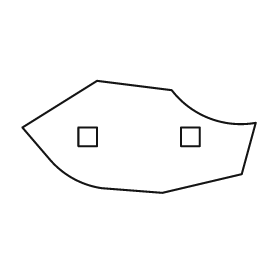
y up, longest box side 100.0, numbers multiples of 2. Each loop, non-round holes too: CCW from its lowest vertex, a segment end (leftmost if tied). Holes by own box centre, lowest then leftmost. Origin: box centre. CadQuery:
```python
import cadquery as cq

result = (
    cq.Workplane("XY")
    .moveTo(10.0, -24.0)
    .lineTo(44.0, -16.0)
    .lineTo(50.0, 6.0)
    .threePointArc((30.0, 8.0), (14.0, 20.0))
    .lineTo(-18.0, 24.0)
    .lineTo(-50.0, 4.0)
    .lineTo(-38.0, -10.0)
    .threePointArc((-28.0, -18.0), (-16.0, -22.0))
    .close()
    .moveTo(-26.0, -4.0)
    .lineTo(-18.0, -4.0)
    .lineTo(-18.0, 4.0)
    .lineTo(-26.0, 4.0)
    .close()
    .moveTo(18.0, -4.0)
    .lineTo(26.0, -4.0)
    .lineTo(26.0, 4.0)
    .lineTo(18.0, 4.0)
    .close()
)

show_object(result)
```